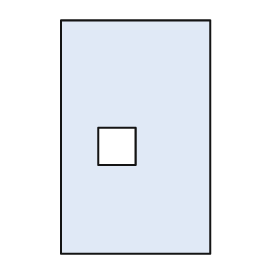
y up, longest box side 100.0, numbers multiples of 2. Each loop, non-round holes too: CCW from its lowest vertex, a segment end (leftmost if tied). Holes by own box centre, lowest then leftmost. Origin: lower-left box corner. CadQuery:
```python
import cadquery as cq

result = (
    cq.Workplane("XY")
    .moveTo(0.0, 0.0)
    .lineTo(64.0, 0.0)
    .lineTo(64.0, 100.0)
    .lineTo(0.0, 100.0)
    .close()
    .moveTo(16.0, 38.0)
    .lineTo(32.0, 38.0)
    .lineTo(32.0, 54.0)
    .lineTo(16.0, 54.0)
    .close()
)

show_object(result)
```